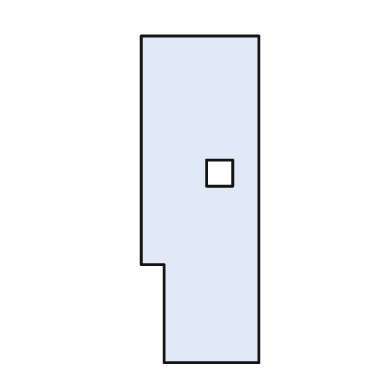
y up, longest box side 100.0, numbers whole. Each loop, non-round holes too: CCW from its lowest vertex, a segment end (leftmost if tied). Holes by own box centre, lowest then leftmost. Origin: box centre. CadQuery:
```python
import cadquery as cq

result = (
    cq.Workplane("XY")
    .moveTo(-11.0, -50.0)
    .lineTo(18.0, -50.0)
    .lineTo(18.0, 50.0)
    .lineTo(-18.0, 50.0)
    .lineTo(-18.0, -20.0)
    .lineTo(-11.0, -20.0)
    .close()
    .moveTo(2.0, 4.0)
    .lineTo(10.0, 4.0)
    .lineTo(10.0, 12.0)
    .lineTo(2.0, 12.0)
    .close()
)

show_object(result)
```